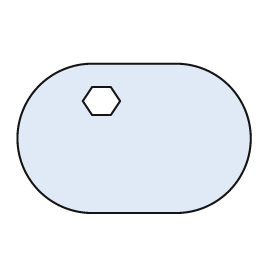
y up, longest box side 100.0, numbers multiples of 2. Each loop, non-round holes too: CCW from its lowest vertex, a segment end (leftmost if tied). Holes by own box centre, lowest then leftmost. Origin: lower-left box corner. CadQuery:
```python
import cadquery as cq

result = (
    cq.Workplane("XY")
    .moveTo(32.0, 0.0)
    .lineTo(68.0, 0.0)
    .threePointArc((100.0, 32.0), (68.0, 64.0))
    .lineTo(32.0, 64.0)
    .threePointArc((0.0, 32.0), (32.0, 0.0))
    .close()
    .moveTo(32.0, 42.0)
    .lineTo(40.0, 42.0)
    .lineTo(44.0, 48.0)
    .lineTo(40.0, 54.0)
    .lineTo(32.0, 54.0)
    .lineTo(28.0, 48.0)
    .close()
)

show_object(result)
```